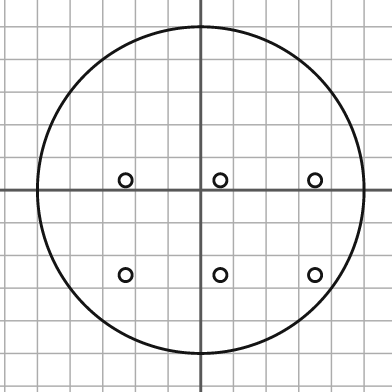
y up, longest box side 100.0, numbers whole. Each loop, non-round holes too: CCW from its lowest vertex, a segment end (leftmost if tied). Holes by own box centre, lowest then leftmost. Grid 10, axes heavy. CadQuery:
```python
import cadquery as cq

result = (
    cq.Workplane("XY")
    .moveTo(0.0, 0.0)
    .circle(50.0)
    .moveTo(-23.0, -26.0)
    .circle(2.0)
    .moveTo(6.0, -26.0)
    .circle(2.0)
    .moveTo(35.0, -26.0)
    .circle(2.0)
    .moveTo(-23.0, 3.0)
    .circle(2.0)
    .moveTo(6.0, 3.0)
    .circle(2.0)
    .moveTo(35.0, 3.0)
    .circle(2.0)
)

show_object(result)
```